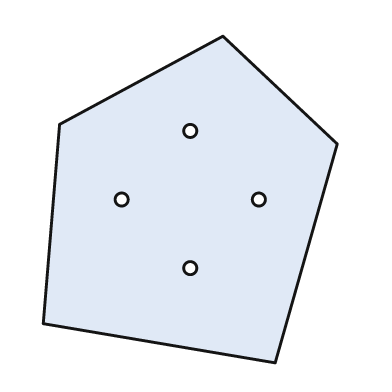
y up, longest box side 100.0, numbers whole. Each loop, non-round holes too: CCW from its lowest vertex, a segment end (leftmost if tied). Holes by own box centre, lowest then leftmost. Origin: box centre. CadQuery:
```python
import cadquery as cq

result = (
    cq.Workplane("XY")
    .moveTo(26.0, -50.0)
    .lineTo(45.0, 17.0)
    .lineTo(10.0, 50.0)
    .lineTo(-40.0, 23.0)
    .lineTo(-45.0, -38.0)
    .close()
    .moveTo(0.0, -21.0)
    .circle(2.0)
    .moveTo(-21.0, 0.0)
    .circle(2.0)
    .moveTo(21.0, 0.0)
    .circle(2.0)
    .moveTo(0.0, 21.0)
    .circle(2.0)
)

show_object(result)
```